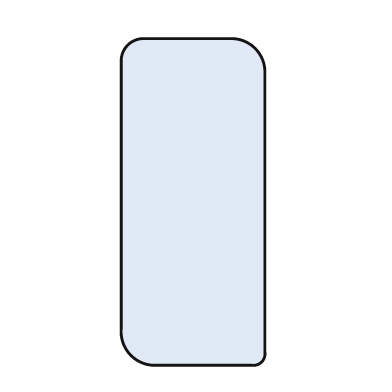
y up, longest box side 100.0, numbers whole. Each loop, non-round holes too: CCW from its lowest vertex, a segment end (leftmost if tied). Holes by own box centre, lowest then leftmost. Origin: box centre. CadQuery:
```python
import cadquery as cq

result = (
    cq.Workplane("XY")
    .moveTo(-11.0, -50.0)
    .lineTo(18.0, -50.0)
    .threePointArc((21.0, -49.0), (22.0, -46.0))
    .lineTo(22.0, 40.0)
    .threePointArc((19.0, 47.0), (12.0, 50.0))
    .lineTo(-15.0, 50.0)
    .threePointArc((-20.0, 48.0), (-22.0, 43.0))
    .lineTo(-22.0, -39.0)
    .threePointArc((-19.0, -47.0), (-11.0, -50.0))
    .close()
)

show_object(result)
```